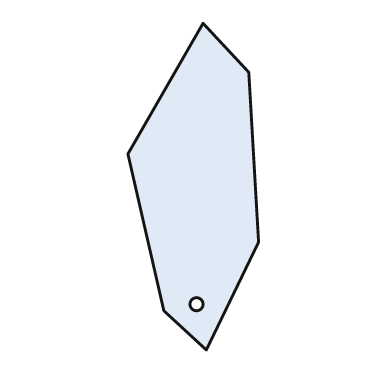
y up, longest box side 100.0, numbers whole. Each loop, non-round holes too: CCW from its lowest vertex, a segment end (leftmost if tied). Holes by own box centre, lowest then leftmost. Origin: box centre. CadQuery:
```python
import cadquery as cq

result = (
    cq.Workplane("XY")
    .moveTo(4.0, -50.0)
    .lineTo(20.0, -17.0)
    .lineTo(17.0, 35.0)
    .lineTo(3.0, 50.0)
    .lineTo(-20.0, 10.0)
    .lineTo(-9.0, -38.0)
    .close()
    .moveTo(1.0, -36.0)
    .circle(2.0)
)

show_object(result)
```